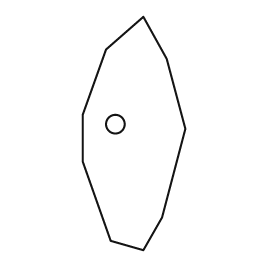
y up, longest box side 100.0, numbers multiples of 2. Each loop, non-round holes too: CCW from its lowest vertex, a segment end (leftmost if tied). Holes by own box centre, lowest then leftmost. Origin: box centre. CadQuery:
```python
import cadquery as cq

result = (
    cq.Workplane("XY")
    .moveTo(4.0, -50.0)
    .lineTo(12.0, -36.0)
    .lineTo(22.0, 2.0)
    .lineTo(14.0, 32.0)
    .lineTo(4.0, 50.0)
    .lineTo(-12.0, 36.0)
    .lineTo(-22.0, 8.0)
    .lineTo(-22.0, -12.0)
    .lineTo(-10.0, -46.0)
    .close()
    .moveTo(-8.0, 4.0)
    .circle(4.0)
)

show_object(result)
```